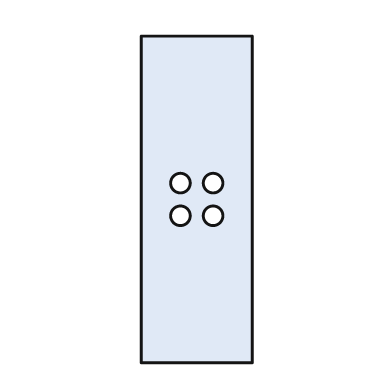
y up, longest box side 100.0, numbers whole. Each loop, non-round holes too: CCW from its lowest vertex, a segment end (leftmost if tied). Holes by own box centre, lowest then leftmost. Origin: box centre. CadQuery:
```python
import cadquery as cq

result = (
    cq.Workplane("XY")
    .moveTo(-17.0, -50.0)
    .lineTo(17.0, -50.0)
    .lineTo(17.0, 50.0)
    .lineTo(-17.0, 50.0)
    .close()
    .moveTo(-5.0, -5.0)
    .circle(3.0)
    .moveTo(5.0, -5.0)
    .circle(3.0)
    .moveTo(-5.0, 5.0)
    .circle(3.0)
    .moveTo(5.0, 5.0)
    .circle(3.0)
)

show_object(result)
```